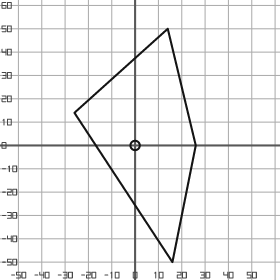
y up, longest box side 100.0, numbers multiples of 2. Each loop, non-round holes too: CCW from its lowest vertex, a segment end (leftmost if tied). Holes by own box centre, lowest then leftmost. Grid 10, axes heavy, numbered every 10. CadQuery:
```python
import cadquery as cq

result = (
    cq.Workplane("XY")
    .moveTo(16.0, -50.0)
    .lineTo(26.0, 0.0)
    .lineTo(14.0, 50.0)
    .lineTo(-26.0, 14.0)
    .close()
    .moveTo(0.0, 0.0)
    .circle(2.0)
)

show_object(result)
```